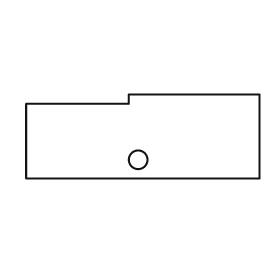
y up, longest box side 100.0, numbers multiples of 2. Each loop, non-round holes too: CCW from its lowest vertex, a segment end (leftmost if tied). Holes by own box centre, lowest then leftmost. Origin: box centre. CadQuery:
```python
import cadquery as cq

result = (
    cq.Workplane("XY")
    .moveTo(-50.0, -18.0)
    .lineTo(50.0, -18.0)
    .lineTo(50.0, 18.0)
    .lineTo(-6.0, 18.0)
    .lineTo(-6.0, 14.0)
    .lineTo(-50.0, 14.0)
    .close()
    .moveTo(-2.0, -10.0)
    .circle(4.0)
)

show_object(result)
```